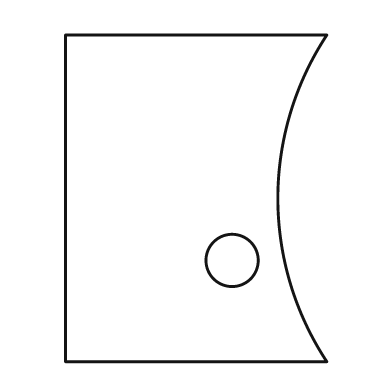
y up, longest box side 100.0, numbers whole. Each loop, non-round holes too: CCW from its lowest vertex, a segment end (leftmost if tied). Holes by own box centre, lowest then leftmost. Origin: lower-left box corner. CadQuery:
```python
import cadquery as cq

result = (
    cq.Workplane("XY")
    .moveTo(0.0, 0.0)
    .lineTo(80.0, 0.0)
    .threePointArc((65.0, 50.0), (80.0, 100.0))
    .lineTo(0.0, 100.0)
    .close()
    .moveTo(51.0, 31.0)
    .circle(8.0)
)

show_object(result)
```